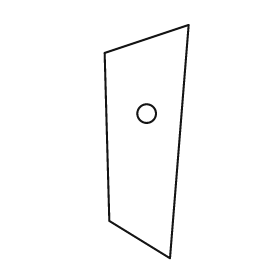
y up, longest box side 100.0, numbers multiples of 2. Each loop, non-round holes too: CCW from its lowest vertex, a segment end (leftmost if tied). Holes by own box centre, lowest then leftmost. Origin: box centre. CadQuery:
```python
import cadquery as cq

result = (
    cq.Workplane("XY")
    .moveTo(10.0, -50.0)
    .lineTo(18.0, 50.0)
    .lineTo(-18.0, 38.0)
    .lineTo(-16.0, -34.0)
    .close()
    .moveTo(0.0, 12.0)
    .circle(4.0)
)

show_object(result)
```